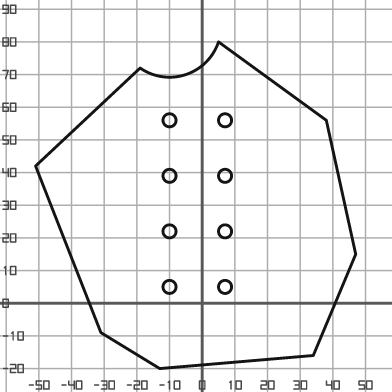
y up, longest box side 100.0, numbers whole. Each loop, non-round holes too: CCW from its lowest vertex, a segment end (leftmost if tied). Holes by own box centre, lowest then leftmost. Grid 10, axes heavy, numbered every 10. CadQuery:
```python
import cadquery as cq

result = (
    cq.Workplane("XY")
    .moveTo(-13.0, -20.0)
    .lineTo(34.0, -16.0)
    .lineTo(47.0, 15.0)
    .lineTo(38.0, 56.0)
    .lineTo(5.0, 80.0)
    .threePointArc((-5.0, 70.0), (-19.0, 72.0))
    .lineTo(-51.0, 42.0)
    .lineTo(-31.0, -9.0)
    .close()
    .moveTo(-10.0, 5.0)
    .circle(2.0)
    .moveTo(7.0, 5.0)
    .circle(2.0)
    .moveTo(-10.0, 22.0)
    .circle(2.0)
    .moveTo(7.0, 22.0)
    .circle(2.0)
    .moveTo(-10.0, 39.0)
    .circle(2.0)
    .moveTo(7.0, 39.0)
    .circle(2.0)
    .moveTo(-10.0, 56.0)
    .circle(2.0)
    .moveTo(7.0, 56.0)
    .circle(2.0)
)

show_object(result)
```